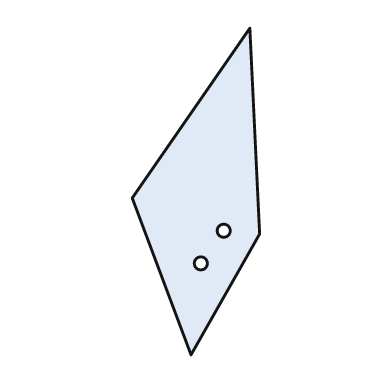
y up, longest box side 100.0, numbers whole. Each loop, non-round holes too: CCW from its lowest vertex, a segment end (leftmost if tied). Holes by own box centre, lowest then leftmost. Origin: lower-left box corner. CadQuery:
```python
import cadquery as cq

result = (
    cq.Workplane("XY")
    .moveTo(18.0, 0.0)
    .lineTo(39.0, 37.0)
    .lineTo(36.0, 100.0)
    .lineTo(0.0, 48.0)
    .close()
    .moveTo(21.0, 28.0)
    .circle(2.0)
    .moveTo(28.0, 38.0)
    .circle(2.0)
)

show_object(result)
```